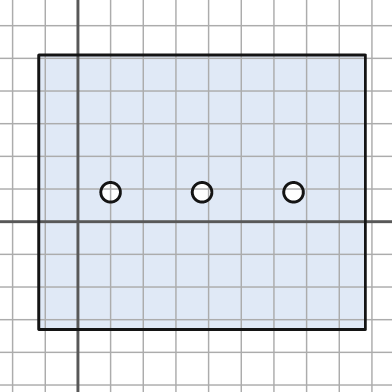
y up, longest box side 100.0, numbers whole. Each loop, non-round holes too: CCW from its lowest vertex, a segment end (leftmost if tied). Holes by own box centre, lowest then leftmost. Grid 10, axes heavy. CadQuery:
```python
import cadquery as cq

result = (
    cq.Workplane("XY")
    .moveTo(-12.0, -33.0)
    .lineTo(88.0, -33.0)
    .lineTo(88.0, 51.0)
    .lineTo(-12.0, 51.0)
    .close()
    .moveTo(10.0, 9.0)
    .circle(3.0)
    .moveTo(38.0, 9.0)
    .circle(3.0)
    .moveTo(66.0, 9.0)
    .circle(3.0)
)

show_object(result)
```